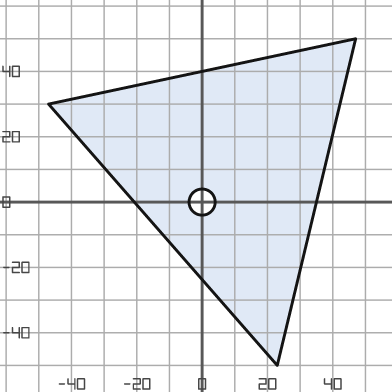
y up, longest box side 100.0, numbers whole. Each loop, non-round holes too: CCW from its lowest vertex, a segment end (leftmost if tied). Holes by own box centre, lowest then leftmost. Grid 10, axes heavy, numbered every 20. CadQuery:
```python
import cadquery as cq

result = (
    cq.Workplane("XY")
    .moveTo(23.0, -50.0)
    .lineTo(47.0, 50.0)
    .lineTo(-47.0, 30.0)
    .close()
    .moveTo(0.0, 0.0)
    .circle(4.0)
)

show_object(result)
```